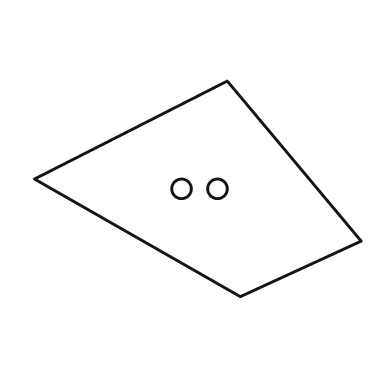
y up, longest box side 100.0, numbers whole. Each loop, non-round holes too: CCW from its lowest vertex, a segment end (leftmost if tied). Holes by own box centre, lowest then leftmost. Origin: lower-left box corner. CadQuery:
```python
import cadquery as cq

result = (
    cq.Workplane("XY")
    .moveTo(63.0, 0.0)
    .lineTo(100.0, 17.0)
    .lineTo(59.0, 66.0)
    .lineTo(0.0, 36.0)
    .close()
    .moveTo(45.0, 33.0)
    .circle(3.0)
    .moveTo(56.0, 33.0)
    .circle(3.0)
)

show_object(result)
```